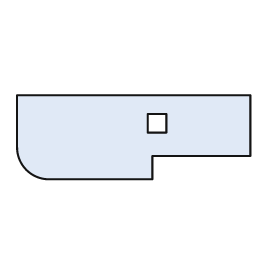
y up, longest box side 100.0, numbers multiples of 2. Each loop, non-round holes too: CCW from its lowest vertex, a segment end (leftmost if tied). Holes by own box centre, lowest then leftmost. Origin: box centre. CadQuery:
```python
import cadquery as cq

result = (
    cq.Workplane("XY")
    .moveTo(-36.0, -18.0)
    .lineTo(8.0, -18.0)
    .lineTo(8.0, -8.0)
    .lineTo(50.0, -8.0)
    .lineTo(50.0, 18.0)
    .lineTo(-50.0, 18.0)
    .lineTo(-50.0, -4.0)
    .threePointArc((-46.0, -14.0), (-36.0, -18.0))
    .close()
    .moveTo(6.0, 2.0)
    .lineTo(14.0, 2.0)
    .lineTo(14.0, 10.0)
    .lineTo(6.0, 10.0)
    .close()
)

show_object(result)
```